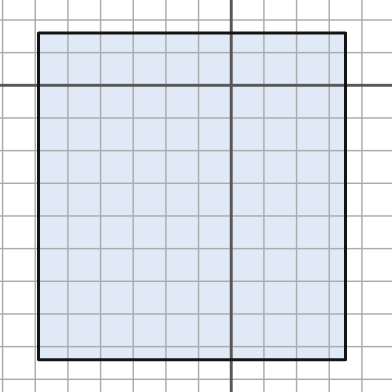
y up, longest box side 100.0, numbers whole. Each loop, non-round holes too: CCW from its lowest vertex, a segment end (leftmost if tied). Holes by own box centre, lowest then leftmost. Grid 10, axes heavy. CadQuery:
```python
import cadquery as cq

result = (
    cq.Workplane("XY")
    .moveTo(-59.0, -84.0)
    .lineTo(35.0, -84.0)
    .lineTo(35.0, 16.0)
    .lineTo(-59.0, 16.0)
    .close()
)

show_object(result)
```